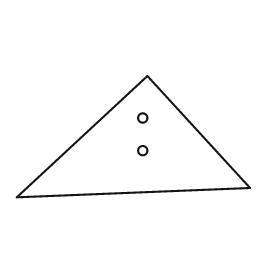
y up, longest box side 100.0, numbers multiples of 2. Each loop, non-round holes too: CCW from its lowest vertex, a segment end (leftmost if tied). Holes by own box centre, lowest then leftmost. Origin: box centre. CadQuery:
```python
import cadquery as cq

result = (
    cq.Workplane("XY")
    .moveTo(-50.0, -26.0)
    .lineTo(50.0, -22.0)
    .lineTo(6.0, 26.0)
    .close()
    .moveTo(4.0, -6.0)
    .circle(2.0)
    .moveTo(4.0, 8.0)
    .circle(2.0)
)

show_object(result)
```